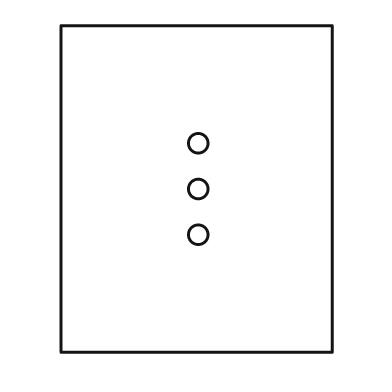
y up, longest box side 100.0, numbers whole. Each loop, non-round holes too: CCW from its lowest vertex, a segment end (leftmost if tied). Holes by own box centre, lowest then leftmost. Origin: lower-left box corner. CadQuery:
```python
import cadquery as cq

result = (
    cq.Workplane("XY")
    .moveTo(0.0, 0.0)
    .lineTo(83.0, 0.0)
    .lineTo(83.0, 100.0)
    .lineTo(0.0, 100.0)
    .close()
    .moveTo(42.0, 36.0)
    .circle(3.0)
    .moveTo(42.0, 50.0)
    .circle(3.0)
    .moveTo(42.0, 64.0)
    .circle(3.0)
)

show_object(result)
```